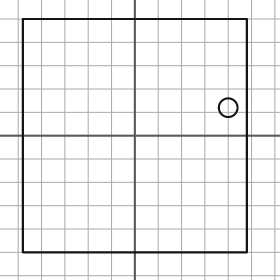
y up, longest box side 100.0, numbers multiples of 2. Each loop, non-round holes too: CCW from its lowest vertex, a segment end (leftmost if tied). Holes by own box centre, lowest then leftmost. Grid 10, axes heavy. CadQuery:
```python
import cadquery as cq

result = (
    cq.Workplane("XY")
    .moveTo(-48.0, -50.0)
    .lineTo(48.0, -50.0)
    .lineTo(48.0, 50.0)
    .lineTo(-48.0, 50.0)
    .close()
    .moveTo(40.0, 12.0)
    .circle(4.0)
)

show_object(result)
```